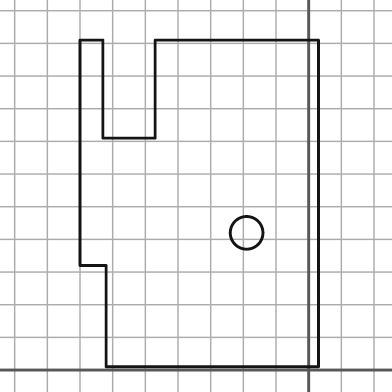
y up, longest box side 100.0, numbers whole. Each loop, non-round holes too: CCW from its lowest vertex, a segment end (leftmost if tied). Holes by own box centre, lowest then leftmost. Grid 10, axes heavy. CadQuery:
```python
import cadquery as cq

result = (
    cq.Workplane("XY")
    .moveTo(-62.0, 1.0)
    .lineTo(3.0, 1.0)
    .lineTo(3.0, 101.0)
    .lineTo(-47.0, 101.0)
    .lineTo(-47.0, 71.0)
    .lineTo(-63.0, 71.0)
    .lineTo(-63.0, 101.0)
    .lineTo(-70.0, 101.0)
    .lineTo(-70.0, 32.0)
    .lineTo(-62.0, 32.0)
    .close()
    .moveTo(-19.0, 42.0)
    .circle(5.0)
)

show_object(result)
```